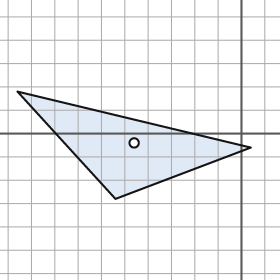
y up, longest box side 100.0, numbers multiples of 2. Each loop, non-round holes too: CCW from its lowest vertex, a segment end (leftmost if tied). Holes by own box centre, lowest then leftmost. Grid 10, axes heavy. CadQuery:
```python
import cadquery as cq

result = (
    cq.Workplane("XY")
    .moveTo(-54.0, -28.0)
    .lineTo(4.0, -6.0)
    .lineTo(-96.0, 18.0)
    .close()
    .moveTo(-46.0, -4.0)
    .circle(2.0)
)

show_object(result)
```